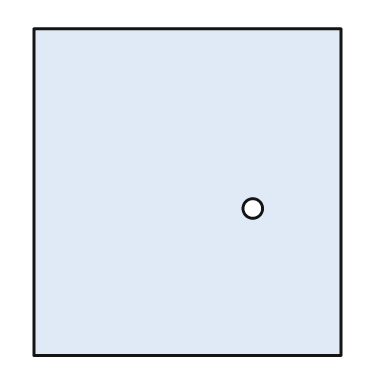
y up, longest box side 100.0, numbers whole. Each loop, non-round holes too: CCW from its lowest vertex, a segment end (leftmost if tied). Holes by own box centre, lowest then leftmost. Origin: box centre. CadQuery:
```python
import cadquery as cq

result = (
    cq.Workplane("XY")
    .moveTo(-47.0, -50.0)
    .lineTo(47.0, -50.0)
    .lineTo(47.0, 50.0)
    .lineTo(-47.0, 50.0)
    .close()
    .moveTo(20.0, -5.0)
    .circle(3.0)
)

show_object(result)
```